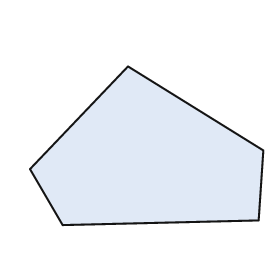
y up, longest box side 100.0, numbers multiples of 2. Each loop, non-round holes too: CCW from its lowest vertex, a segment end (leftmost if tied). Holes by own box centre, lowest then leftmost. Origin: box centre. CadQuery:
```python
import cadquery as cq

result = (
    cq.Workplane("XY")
    .moveTo(-36.0, -34.0)
    .lineTo(48.0, -32.0)
    .lineTo(50.0, -2.0)
    .lineTo(-8.0, 34.0)
    .lineTo(-50.0, -10.0)
    .close()
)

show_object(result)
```